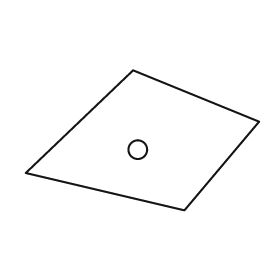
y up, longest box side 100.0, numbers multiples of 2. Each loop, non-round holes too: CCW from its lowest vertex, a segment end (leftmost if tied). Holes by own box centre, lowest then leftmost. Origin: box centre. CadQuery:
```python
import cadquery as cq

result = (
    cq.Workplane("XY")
    .moveTo(18.0, -30.0)
    .lineTo(50.0, 8.0)
    .lineTo(-4.0, 30.0)
    .lineTo(-50.0, -14.0)
    .close()
    .moveTo(-2.0, -4.0)
    .circle(4.0)
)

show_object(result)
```